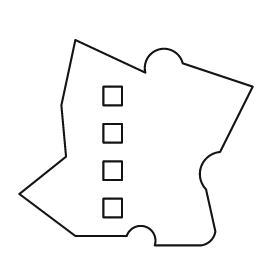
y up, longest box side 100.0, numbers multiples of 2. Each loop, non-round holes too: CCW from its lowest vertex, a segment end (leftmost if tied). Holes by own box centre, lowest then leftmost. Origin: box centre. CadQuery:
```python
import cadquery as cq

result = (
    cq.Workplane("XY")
    .moveTo(8.0, -44.0)
    .lineTo(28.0, -44.0)
    .threePointArc((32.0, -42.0), (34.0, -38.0))
    .lineTo(30.0, -20.0)
    .threePointArc((28.0, -10.0), (36.0, -4.0))
    .lineTo(50.0, 24.0)
    .lineTo(20.0, 34.0)
    .threePointArc((10.0, 40.0), (4.0, 30.0))
    .lineTo(-26.0, 44.0)
    .lineTo(-32.0, 16.0)
    .lineTo(-30.0, -6.0)
    .lineTo(-50.0, -22.0)
    .lineTo(-26.0, -40.0)
    .lineTo(-4.0, -40.0)
    .threePointArc((4.0, -36.0), (8.0, -44.0))
    .close()
    .moveTo(-14.0, -32.0)
    .lineTo(-6.0, -32.0)
    .lineTo(-6.0, -24.0)
    .lineTo(-14.0, -24.0)
    .close()
    .moveTo(-14.0, -16.0)
    .lineTo(-6.0, -16.0)
    .lineTo(-6.0, -8.0)
    .lineTo(-14.0, -8.0)
    .close()
    .moveTo(-14.0, 0.0)
    .lineTo(-6.0, 0.0)
    .lineTo(-6.0, 8.0)
    .lineTo(-14.0, 8.0)
    .close()
    .moveTo(-14.0, 16.0)
    .lineTo(-6.0, 16.0)
    .lineTo(-6.0, 24.0)
    .lineTo(-14.0, 24.0)
    .close()
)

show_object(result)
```